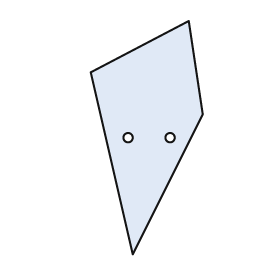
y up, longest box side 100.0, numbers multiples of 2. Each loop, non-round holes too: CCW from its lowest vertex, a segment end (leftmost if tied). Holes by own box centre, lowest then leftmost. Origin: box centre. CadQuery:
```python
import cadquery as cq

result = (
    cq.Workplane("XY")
    .moveTo(-6.0, -50.0)
    .lineTo(24.0, 10.0)
    .lineTo(18.0, 50.0)
    .lineTo(-24.0, 28.0)
    .close()
    .moveTo(-8.0, 0.0)
    .circle(2.0)
    .moveTo(10.0, 0.0)
    .circle(2.0)
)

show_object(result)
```